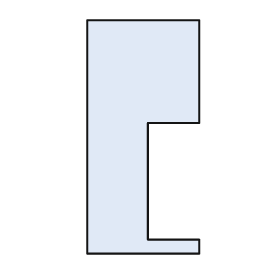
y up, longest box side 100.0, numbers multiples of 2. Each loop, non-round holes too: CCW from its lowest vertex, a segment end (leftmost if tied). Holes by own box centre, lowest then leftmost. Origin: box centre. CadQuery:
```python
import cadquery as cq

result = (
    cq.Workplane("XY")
    .moveTo(-24.0, -50.0)
    .lineTo(24.0, -50.0)
    .lineTo(24.0, -44.0)
    .lineTo(2.0, -44.0)
    .lineTo(2.0, 6.0)
    .lineTo(24.0, 6.0)
    .lineTo(24.0, 50.0)
    .lineTo(-24.0, 50.0)
    .close()
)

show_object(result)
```